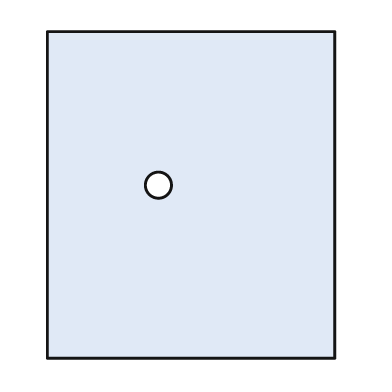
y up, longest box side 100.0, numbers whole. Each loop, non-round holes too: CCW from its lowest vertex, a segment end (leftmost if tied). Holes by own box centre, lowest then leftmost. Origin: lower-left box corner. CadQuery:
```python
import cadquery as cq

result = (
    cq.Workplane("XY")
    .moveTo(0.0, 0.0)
    .lineTo(88.0, 0.0)
    .lineTo(88.0, 100.0)
    .lineTo(0.0, 100.0)
    .close()
    .moveTo(34.0, 53.0)
    .circle(4.0)
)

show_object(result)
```